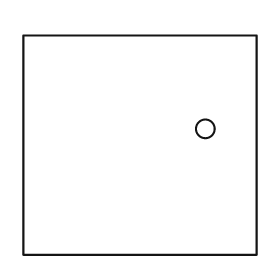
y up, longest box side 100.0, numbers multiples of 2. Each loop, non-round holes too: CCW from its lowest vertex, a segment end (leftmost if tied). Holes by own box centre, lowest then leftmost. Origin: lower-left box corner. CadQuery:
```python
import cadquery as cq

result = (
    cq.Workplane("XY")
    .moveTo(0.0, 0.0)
    .lineTo(100.0, 0.0)
    .lineTo(100.0, 94.0)
    .lineTo(0.0, 94.0)
    .close()
    .moveTo(78.0, 54.0)
    .circle(4.0)
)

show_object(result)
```